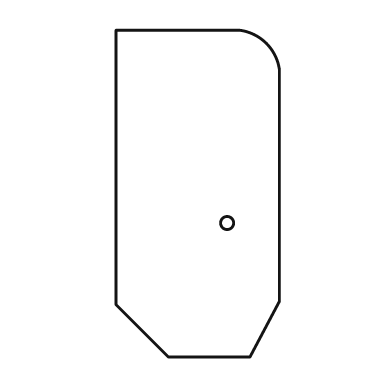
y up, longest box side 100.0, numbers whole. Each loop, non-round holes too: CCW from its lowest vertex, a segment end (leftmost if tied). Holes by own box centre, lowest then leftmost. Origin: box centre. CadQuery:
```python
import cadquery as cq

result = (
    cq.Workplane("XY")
    .moveTo(-9.0, -50.0)
    .lineTo(16.0, -50.0)
    .lineTo(25.0, -33.0)
    .lineTo(25.0, 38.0)
    .threePointArc((21.0, 46.0), (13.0, 50.0))
    .lineTo(-25.0, 50.0)
    .lineTo(-25.0, -34.0)
    .close()
    .moveTo(9.0, -9.0)
    .circle(2.0)
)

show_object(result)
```